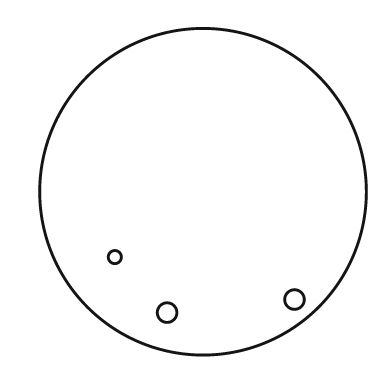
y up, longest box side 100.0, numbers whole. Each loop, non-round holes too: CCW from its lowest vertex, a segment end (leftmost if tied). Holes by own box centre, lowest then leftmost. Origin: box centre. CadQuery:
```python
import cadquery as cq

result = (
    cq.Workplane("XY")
    .moveTo(0.0, 0.0)
    .circle(50.0)
    .moveTo(-11.0, -37.0)
    .circle(3.0)
    .moveTo(28.0, -33.0)
    .circle(3.0)
    .moveTo(-27.0, -20.0)
    .circle(2.0)
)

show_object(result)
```